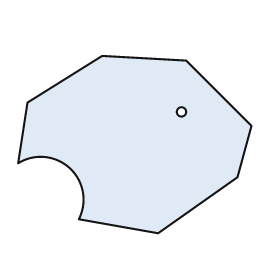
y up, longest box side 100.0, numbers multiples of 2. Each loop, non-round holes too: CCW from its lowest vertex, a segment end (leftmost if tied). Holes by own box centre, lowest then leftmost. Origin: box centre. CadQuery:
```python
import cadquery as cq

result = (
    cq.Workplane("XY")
    .moveTo(10.0, -38.0)
    .lineTo(44.0, -14.0)
    .lineTo(50.0, 8.0)
    .lineTo(22.0, 36.0)
    .lineTo(-14.0, 38.0)
    .lineTo(-46.0, 18.0)
    .lineTo(-50.0, -8.0)
    .threePointArc((-28.0, -10.0), (-24.0, -32.0))
    .close()
    .moveTo(20.0, 14.0)
    .circle(2.0)
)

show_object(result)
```